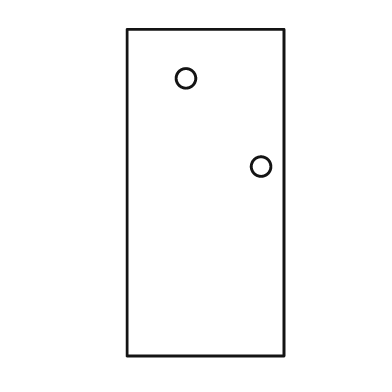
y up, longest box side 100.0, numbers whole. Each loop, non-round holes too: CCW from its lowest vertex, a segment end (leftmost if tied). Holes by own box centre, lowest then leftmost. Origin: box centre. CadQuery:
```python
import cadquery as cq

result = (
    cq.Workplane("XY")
    .moveTo(-24.0, -50.0)
    .lineTo(24.0, -50.0)
    .lineTo(24.0, 50.0)
    .lineTo(-24.0, 50.0)
    .close()
    .moveTo(17.0, 8.0)
    .circle(3.0)
    .moveTo(-6.0, 35.0)
    .circle(3.0)
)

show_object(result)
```